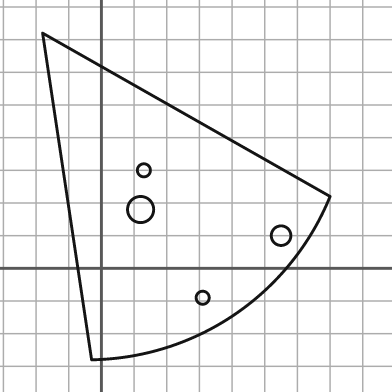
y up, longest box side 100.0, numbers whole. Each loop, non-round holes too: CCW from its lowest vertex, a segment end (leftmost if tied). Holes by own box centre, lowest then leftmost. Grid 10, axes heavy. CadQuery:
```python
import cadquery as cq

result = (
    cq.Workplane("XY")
    .moveTo(-3.0, -28.0)
    .threePointArc((41.0, -14.0), (70.0, 22.0))
    .lineTo(-18.0, 72.0)
    .close()
    .moveTo(31.0, -9.0)
    .circle(2.0)
    .moveTo(55.0, 10.0)
    .circle(3.0)
    .moveTo(12.0, 18.0)
    .circle(4.0)
    .moveTo(13.0, 30.0)
    .circle(2.0)
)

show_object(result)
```